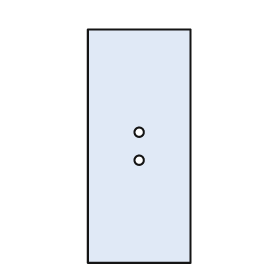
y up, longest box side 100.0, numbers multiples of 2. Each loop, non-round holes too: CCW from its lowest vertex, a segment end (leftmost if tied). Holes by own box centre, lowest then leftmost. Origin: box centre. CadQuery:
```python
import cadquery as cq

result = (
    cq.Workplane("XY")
    .moveTo(-22.0, -50.0)
    .lineTo(22.0, -50.0)
    .lineTo(22.0, 50.0)
    .lineTo(-22.0, 50.0)
    .close()
    .moveTo(0.0, -6.0)
    .circle(2.0)
    .moveTo(0.0, 6.0)
    .circle(2.0)
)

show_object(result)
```